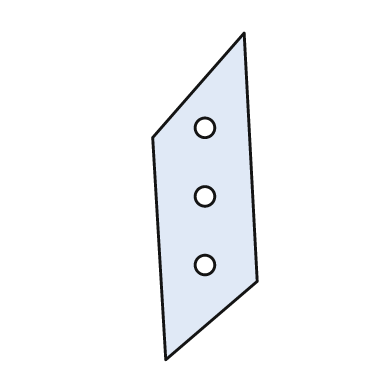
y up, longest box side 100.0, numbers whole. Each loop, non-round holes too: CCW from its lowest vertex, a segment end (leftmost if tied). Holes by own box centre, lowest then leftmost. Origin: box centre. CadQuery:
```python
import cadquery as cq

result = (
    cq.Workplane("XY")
    .moveTo(-12.0, -50.0)
    .lineTo(16.0, -26.0)
    .lineTo(12.0, 50.0)
    .lineTo(-16.0, 18.0)
    .close()
    .moveTo(0.0, -21.0)
    .circle(3.0)
    .moveTo(0.0, 0.0)
    .circle(3.0)
    .moveTo(0.0, 21.0)
    .circle(3.0)
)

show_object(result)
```